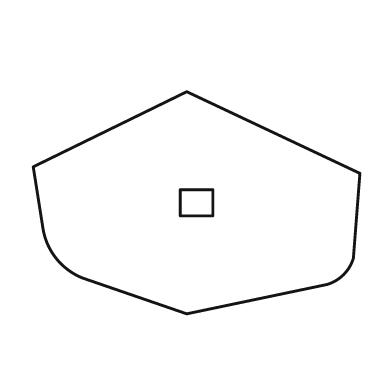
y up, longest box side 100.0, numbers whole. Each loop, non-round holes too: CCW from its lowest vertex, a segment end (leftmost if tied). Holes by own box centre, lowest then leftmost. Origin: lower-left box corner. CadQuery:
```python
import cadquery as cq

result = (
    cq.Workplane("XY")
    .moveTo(47.0, 0.0)
    .lineTo(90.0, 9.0)
    .threePointArc((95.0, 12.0), (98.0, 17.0))
    .lineTo(100.0, 43.0)
    .lineTo(47.0, 68.0)
    .lineTo(0.0, 45.0)
    .lineTo(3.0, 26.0)
    .threePointArc((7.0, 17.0), (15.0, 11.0))
    .close()
    .moveTo(45.0, 30.0)
    .lineTo(55.0, 30.0)
    .lineTo(55.0, 38.0)
    .lineTo(45.0, 38.0)
    .close()
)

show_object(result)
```